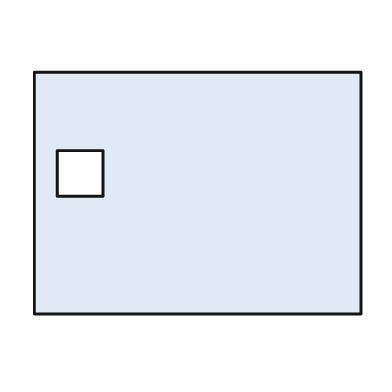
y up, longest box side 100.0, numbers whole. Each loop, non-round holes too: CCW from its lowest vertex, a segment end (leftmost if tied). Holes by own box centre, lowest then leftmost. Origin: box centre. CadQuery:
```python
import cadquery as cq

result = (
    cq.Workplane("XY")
    .moveTo(-50.0, -37.0)
    .lineTo(50.0, -37.0)
    .lineTo(50.0, 37.0)
    .lineTo(-50.0, 37.0)
    .close()
    .moveTo(-43.0, -1.0)
    .lineTo(-29.0, -1.0)
    .lineTo(-29.0, 13.0)
    .lineTo(-43.0, 13.0)
    .close()
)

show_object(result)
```